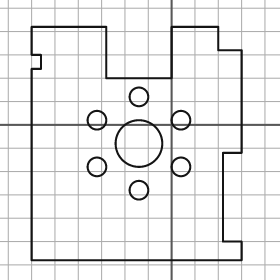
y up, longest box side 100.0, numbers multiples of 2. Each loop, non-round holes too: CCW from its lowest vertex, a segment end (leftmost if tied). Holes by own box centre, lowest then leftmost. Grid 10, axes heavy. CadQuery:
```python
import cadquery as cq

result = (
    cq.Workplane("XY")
    .moveTo(-60.0, -58.0)
    .lineTo(30.0, -58.0)
    .lineTo(30.0, -50.0)
    .lineTo(22.0, -50.0)
    .lineTo(22.0, -12.0)
    .lineTo(30.0, -12.0)
    .lineTo(30.0, 32.0)
    .lineTo(20.0, 32.0)
    .lineTo(20.0, 42.0)
    .lineTo(0.0, 42.0)
    .lineTo(0.0, 20.0)
    .lineTo(-28.0, 20.0)
    .lineTo(-28.0, 42.0)
    .lineTo(-60.0, 42.0)
    .lineTo(-60.0, 30.0)
    .lineTo(-56.0, 30.0)
    .lineTo(-56.0, 24.0)
    .lineTo(-60.0, 24.0)
    .close()
    .moveTo(-14.0, -28.0)
    .circle(4.0)
    .moveTo(-32.0, -18.0)
    .circle(4.0)
    .moveTo(4.0, -18.0)
    .circle(4.0)
    .moveTo(-14.0, -8.0)
    .circle(10.0)
    .moveTo(-32.0, 2.0)
    .circle(4.0)
    .moveTo(4.0, 2.0)
    .circle(4.0)
    .moveTo(-14.0, 12.0)
    .circle(4.0)
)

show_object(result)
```